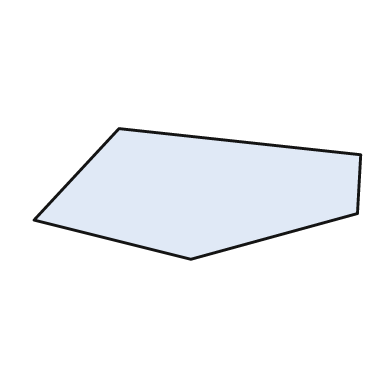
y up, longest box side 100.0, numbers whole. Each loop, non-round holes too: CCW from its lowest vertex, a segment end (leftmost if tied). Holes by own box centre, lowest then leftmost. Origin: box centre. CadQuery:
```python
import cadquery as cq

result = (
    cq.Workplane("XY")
    .moveTo(-2.0, -20.0)
    .lineTo(49.0, -6.0)
    .lineTo(50.0, 12.0)
    .lineTo(-24.0, 20.0)
    .lineTo(-50.0, -8.0)
    .close()
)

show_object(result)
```